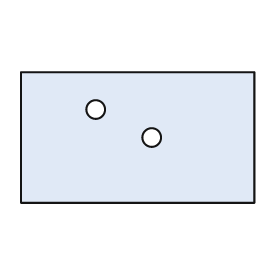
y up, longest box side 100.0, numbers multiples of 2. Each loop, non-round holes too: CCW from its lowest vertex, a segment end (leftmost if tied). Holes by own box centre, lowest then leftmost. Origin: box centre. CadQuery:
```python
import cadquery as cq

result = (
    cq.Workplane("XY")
    .moveTo(-50.0, -28.0)
    .lineTo(50.0, -28.0)
    .lineTo(50.0, 28.0)
    .lineTo(-50.0, 28.0)
    .close()
    .moveTo(6.0, 0.0)
    .circle(4.0)
    .moveTo(-18.0, 12.0)
    .circle(4.0)
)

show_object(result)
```